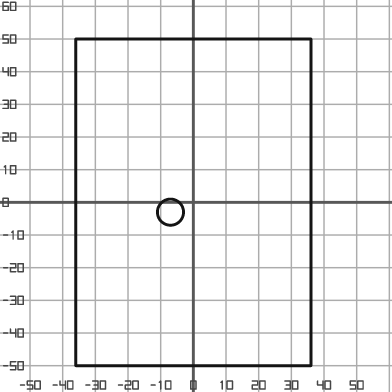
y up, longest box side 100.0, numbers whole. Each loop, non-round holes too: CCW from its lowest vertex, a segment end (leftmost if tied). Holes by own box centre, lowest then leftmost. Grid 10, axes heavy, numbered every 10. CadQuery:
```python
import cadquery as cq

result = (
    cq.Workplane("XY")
    .moveTo(-36.0, -50.0)
    .lineTo(36.0, -50.0)
    .lineTo(36.0, 50.0)
    .lineTo(-36.0, 50.0)
    .close()
    .moveTo(-7.0, -3.0)
    .circle(4.0)
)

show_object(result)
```